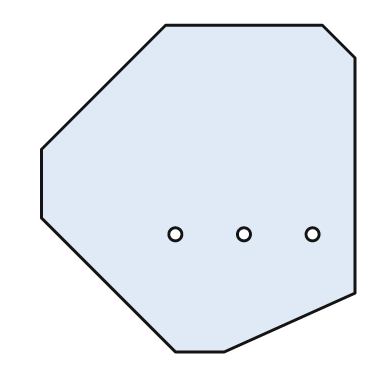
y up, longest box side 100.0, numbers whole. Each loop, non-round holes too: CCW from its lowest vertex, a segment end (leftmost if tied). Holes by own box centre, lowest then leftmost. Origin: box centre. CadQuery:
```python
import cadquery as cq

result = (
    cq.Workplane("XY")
    .moveTo(-7.0, -50.0)
    .lineTo(8.0, -50.0)
    .lineTo(48.0, -32.0)
    .lineTo(48.0, 40.0)
    .lineTo(38.0, 50.0)
    .lineTo(-10.0, 50.0)
    .lineTo(-48.0, 12.0)
    .lineTo(-48.0, -9.0)
    .close()
    .moveTo(-7.0, -14.0)
    .circle(2.0)
    .moveTo(14.0, -14.0)
    .circle(2.0)
    .moveTo(35.0, -14.0)
    .circle(2.0)
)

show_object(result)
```